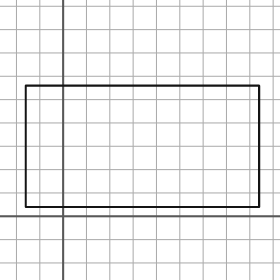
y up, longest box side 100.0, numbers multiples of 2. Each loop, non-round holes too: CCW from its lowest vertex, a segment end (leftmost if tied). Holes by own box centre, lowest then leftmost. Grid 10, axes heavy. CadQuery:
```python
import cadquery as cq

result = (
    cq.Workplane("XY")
    .moveTo(-16.0, 4.0)
    .lineTo(84.0, 4.0)
    .lineTo(84.0, 56.0)
    .lineTo(-16.0, 56.0)
    .close()
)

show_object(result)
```